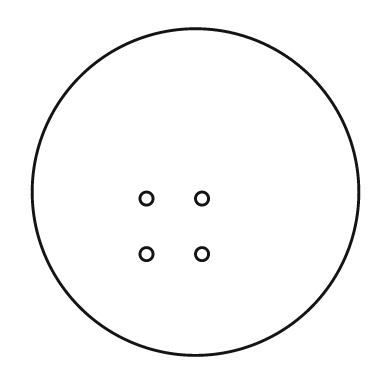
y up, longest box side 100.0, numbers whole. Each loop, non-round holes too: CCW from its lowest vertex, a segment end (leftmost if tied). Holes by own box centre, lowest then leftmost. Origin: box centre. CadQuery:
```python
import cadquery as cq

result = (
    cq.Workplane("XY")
    .moveTo(0.0, 0.0)
    .circle(50.0)
    .moveTo(-15.0, -19.0)
    .circle(2.0)
    .moveTo(2.0, -19.0)
    .circle(2.0)
    .moveTo(-15.0, -2.0)
    .circle(2.0)
    .moveTo(2.0, -2.0)
    .circle(2.0)
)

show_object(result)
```